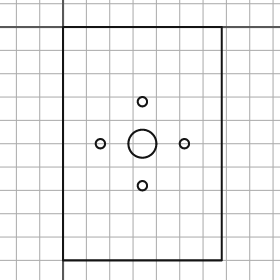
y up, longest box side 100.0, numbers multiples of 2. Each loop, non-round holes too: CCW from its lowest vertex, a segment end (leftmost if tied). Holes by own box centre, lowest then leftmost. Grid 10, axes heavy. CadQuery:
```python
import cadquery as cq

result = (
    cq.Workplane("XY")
    .moveTo(0.0, -100.0)
    .lineTo(68.0, -100.0)
    .lineTo(68.0, 0.0)
    .lineTo(0.0, 0.0)
    .close()
    .moveTo(34.0, -68.0)
    .circle(2.0)
    .moveTo(16.0, -50.0)
    .circle(2.0)
    .moveTo(34.0, -50.0)
    .circle(6.0)
    .moveTo(52.0, -50.0)
    .circle(2.0)
    .moveTo(34.0, -32.0)
    .circle(2.0)
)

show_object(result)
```